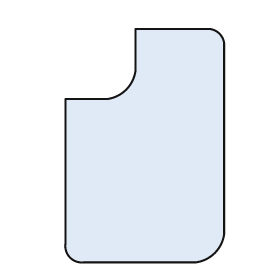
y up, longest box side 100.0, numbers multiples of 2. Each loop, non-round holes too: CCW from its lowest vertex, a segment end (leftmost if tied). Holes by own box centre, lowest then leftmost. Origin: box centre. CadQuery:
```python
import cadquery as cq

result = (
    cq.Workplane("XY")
    .moveTo(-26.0, -50.0)
    .lineTo(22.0, -50.0)
    .threePointArc((30.0, -46.0), (34.0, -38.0))
    .lineTo(34.0, 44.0)
    .threePointArc((32.0, 48.0), (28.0, 50.0))
    .lineTo(-4.0, 50.0)
    .lineTo(-4.0, 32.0)
    .threePointArc((-8.0, 24.0), (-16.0, 20.0))
    .lineTo(-34.0, 20.0)
    .lineTo(-34.0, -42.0)
    .threePointArc((-32.0, -48.0), (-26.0, -50.0))
    .close()
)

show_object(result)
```